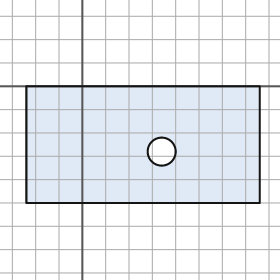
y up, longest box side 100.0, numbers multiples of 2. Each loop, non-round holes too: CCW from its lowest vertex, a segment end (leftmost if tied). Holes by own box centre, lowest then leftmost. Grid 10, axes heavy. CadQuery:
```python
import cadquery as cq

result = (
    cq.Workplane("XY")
    .moveTo(-24.0, -50.0)
    .lineTo(76.0, -50.0)
    .lineTo(76.0, 0.0)
    .lineTo(-24.0, 0.0)
    .close()
    .moveTo(34.0, -28.0)
    .circle(6.0)
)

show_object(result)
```